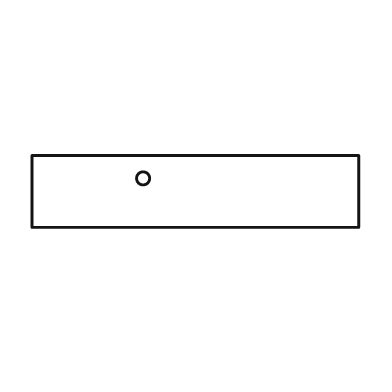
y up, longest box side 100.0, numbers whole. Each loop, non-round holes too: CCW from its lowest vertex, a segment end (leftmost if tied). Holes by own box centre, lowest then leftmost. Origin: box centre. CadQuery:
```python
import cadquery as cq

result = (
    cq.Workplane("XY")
    .moveTo(-50.0, -11.0)
    .lineTo(50.0, -11.0)
    .lineTo(50.0, 11.0)
    .lineTo(-50.0, 11.0)
    .close()
    .moveTo(-16.0, 4.0)
    .circle(2.0)
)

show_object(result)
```